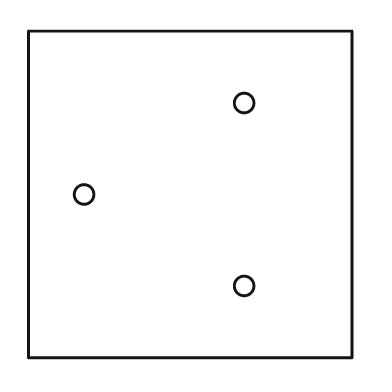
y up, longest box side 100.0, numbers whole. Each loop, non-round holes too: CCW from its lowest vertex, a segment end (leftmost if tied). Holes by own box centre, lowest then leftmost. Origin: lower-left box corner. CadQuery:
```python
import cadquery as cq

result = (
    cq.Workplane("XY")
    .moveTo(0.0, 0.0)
    .lineTo(99.0, 0.0)
    .lineTo(99.0, 100.0)
    .lineTo(0.0, 100.0)
    .close()
    .moveTo(66.0, 22.0)
    .circle(3.0)
    .moveTo(17.0, 50.0)
    .circle(3.0)
    .moveTo(66.0, 78.0)
    .circle(3.0)
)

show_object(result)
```